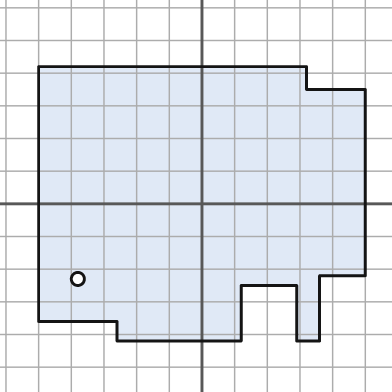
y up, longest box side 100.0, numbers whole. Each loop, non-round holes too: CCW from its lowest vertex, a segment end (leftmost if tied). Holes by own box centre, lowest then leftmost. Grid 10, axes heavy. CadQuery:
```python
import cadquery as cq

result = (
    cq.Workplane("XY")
    .moveTo(-26.0, -42.0)
    .lineTo(12.0, -42.0)
    .lineTo(12.0, -25.0)
    .lineTo(29.0, -25.0)
    .lineTo(29.0, -42.0)
    .lineTo(36.0, -42.0)
    .lineTo(36.0, -22.0)
    .lineTo(50.0, -22.0)
    .lineTo(50.0, 35.0)
    .lineTo(32.0, 35.0)
    .lineTo(32.0, 42.0)
    .lineTo(-50.0, 42.0)
    .lineTo(-50.0, -36.0)
    .lineTo(-26.0, -36.0)
    .close()
    .moveTo(-38.0, -23.0)
    .circle(2.0)
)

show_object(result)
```